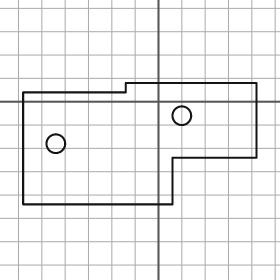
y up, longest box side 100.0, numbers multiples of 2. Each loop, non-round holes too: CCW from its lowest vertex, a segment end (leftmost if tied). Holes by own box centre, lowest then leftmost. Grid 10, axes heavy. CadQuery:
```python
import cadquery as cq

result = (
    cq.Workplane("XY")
    .moveTo(-58.0, -44.0)
    .lineTo(6.0, -44.0)
    .lineTo(6.0, -24.0)
    .lineTo(42.0, -24.0)
    .lineTo(42.0, 8.0)
    .lineTo(-14.0, 8.0)
    .lineTo(-14.0, 4.0)
    .lineTo(-58.0, 4.0)
    .close()
    .moveTo(-44.0, -18.0)
    .circle(4.0)
    .moveTo(10.0, -6.0)
    .circle(4.0)
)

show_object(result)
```